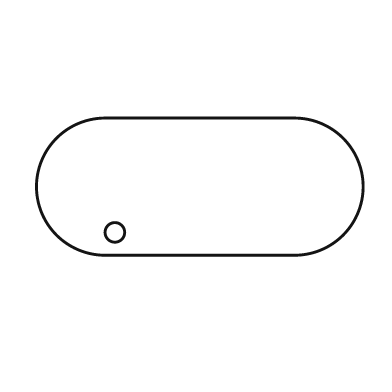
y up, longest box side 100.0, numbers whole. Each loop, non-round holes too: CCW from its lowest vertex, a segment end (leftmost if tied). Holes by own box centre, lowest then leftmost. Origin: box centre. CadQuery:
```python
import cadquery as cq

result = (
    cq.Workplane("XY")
    .moveTo(-29.0, -21.0)
    .lineTo(29.0, -21.0)
    .threePointArc((50.0, 0.0), (29.0, 21.0))
    .lineTo(-29.0, 21.0)
    .threePointArc((-50.0, 0.0), (-29.0, -21.0))
    .close()
    .moveTo(-26.0, -14.0)
    .circle(3.0)
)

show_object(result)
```